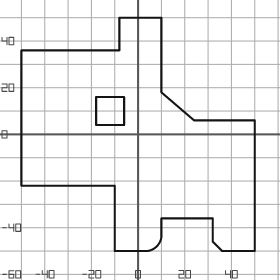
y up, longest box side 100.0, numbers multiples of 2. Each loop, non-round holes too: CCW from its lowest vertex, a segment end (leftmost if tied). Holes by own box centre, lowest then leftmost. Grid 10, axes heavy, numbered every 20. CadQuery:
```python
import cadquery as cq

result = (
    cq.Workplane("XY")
    .moveTo(-10.0, -50.0)
    .lineTo(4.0, -50.0)
    .threePointArc((8.0, -48.0), (10.0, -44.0))
    .lineTo(10.0, -36.0)
    .lineTo(32.0, -36.0)
    .lineTo(32.0, -46.0)
    .lineTo(36.0, -50.0)
    .lineTo(50.0, -50.0)
    .lineTo(50.0, 6.0)
    .lineTo(24.0, 6.0)
    .lineTo(10.0, 18.0)
    .lineTo(10.0, 50.0)
    .lineTo(-8.0, 50.0)
    .lineTo(-8.0, 36.0)
    .lineTo(-50.0, 36.0)
    .lineTo(-50.0, -22.0)
    .lineTo(-10.0, -22.0)
    .close()
    .moveTo(-18.0, 4.0)
    .lineTo(-6.0, 4.0)
    .lineTo(-6.0, 16.0)
    .lineTo(-18.0, 16.0)
    .close()
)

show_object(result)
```